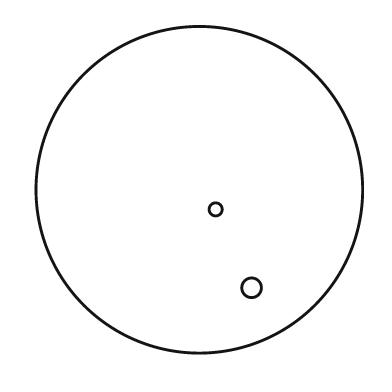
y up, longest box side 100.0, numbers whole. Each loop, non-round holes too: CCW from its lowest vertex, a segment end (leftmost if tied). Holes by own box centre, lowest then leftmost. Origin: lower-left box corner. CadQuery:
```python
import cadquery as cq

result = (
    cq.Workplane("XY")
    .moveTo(50.0, 50.0)
    .circle(50.0)
    .moveTo(66.0, 20.0)
    .circle(3.0)
    .moveTo(55.0, 44.0)
    .circle(2.0)
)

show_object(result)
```